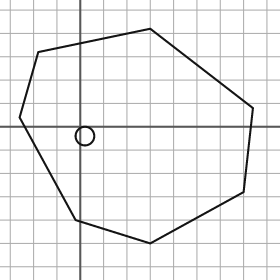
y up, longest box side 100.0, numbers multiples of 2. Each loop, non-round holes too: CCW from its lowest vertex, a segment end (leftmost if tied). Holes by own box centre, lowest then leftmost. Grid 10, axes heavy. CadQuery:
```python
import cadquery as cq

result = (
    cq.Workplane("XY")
    .moveTo(30.0, -50.0)
    .lineTo(70.0, -28.0)
    .lineTo(74.0, 8.0)
    .lineTo(30.0, 42.0)
    .lineTo(-18.0, 32.0)
    .lineTo(-26.0, 4.0)
    .lineTo(-2.0, -40.0)
    .close()
    .moveTo(2.0, -4.0)
    .circle(4.0)
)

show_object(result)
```